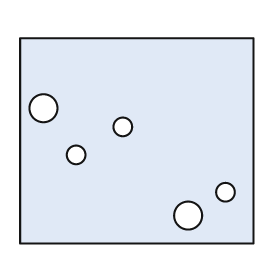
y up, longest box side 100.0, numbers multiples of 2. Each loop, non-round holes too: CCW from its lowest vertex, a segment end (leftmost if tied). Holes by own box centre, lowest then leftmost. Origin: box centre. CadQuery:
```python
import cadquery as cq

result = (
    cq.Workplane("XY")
    .moveTo(-50.0, -44.0)
    .lineTo(50.0, -44.0)
    .lineTo(50.0, 44.0)
    .lineTo(-50.0, 44.0)
    .close()
    .moveTo(22.0, -32.0)
    .circle(6.0)
    .moveTo(38.0, -22.0)
    .circle(4.0)
    .moveTo(-26.0, -6.0)
    .circle(4.0)
    .moveTo(-6.0, 6.0)
    .circle(4.0)
    .moveTo(-40.0, 14.0)
    .circle(6.0)
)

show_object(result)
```